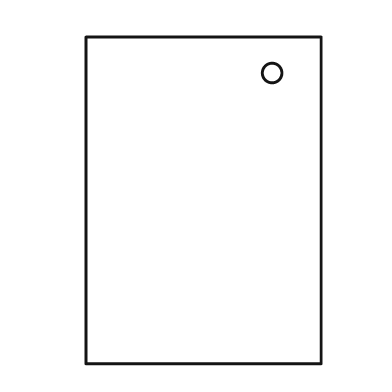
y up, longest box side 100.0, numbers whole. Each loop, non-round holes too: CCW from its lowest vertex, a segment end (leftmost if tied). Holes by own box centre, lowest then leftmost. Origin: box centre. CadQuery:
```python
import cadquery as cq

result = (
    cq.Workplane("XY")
    .moveTo(-36.0, -50.0)
    .lineTo(36.0, -50.0)
    .lineTo(36.0, 50.0)
    .lineTo(-36.0, 50.0)
    .close()
    .moveTo(21.0, 39.0)
    .circle(3.0)
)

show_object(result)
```